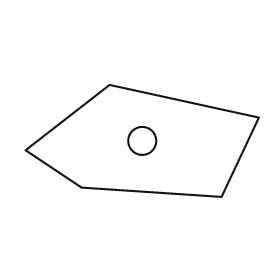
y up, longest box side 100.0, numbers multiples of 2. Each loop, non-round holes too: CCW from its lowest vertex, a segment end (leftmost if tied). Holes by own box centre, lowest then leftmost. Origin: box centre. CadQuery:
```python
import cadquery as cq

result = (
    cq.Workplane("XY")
    .moveTo(34.0, -24.0)
    .lineTo(50.0, 10.0)
    .lineTo(-14.0, 24.0)
    .lineTo(-50.0, -4.0)
    .lineTo(-26.0, -20.0)
    .close()
    .moveTo(0.0, 0.0)
    .circle(6.0)
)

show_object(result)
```